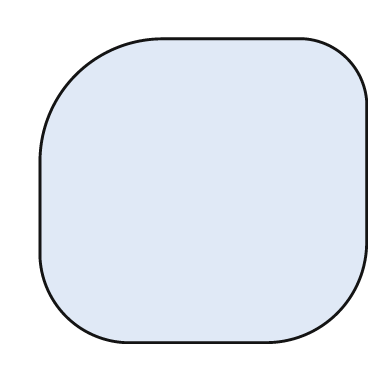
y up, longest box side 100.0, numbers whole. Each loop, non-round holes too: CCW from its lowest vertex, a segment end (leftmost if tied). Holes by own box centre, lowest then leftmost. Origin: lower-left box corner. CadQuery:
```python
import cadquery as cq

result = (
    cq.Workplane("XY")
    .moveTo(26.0, 0.0)
    .lineTo(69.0, 0.0)
    .threePointArc((91.0, 9.0), (100.0, 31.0))
    .lineTo(100.0, 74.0)
    .threePointArc((94.0, 87.0), (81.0, 93.0))
    .lineTo(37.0, 93.0)
    .threePointArc((11.0, 82.0), (0.0, 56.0))
    .lineTo(0.0, 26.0)
    .threePointArc((8.0, 8.0), (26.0, 0.0))
    .close()
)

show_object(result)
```